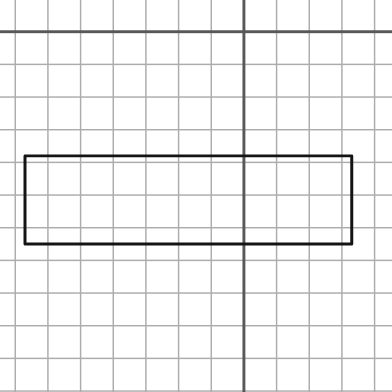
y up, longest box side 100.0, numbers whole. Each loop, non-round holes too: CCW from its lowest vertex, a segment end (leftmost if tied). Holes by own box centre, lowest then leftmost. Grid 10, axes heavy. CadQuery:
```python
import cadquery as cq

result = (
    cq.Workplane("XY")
    .moveTo(-67.0, -65.0)
    .lineTo(33.0, -65.0)
    .lineTo(33.0, -38.0)
    .lineTo(-67.0, -38.0)
    .close()
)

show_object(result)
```